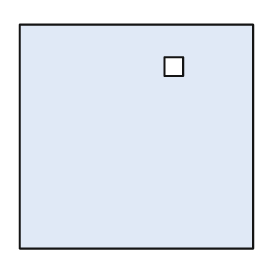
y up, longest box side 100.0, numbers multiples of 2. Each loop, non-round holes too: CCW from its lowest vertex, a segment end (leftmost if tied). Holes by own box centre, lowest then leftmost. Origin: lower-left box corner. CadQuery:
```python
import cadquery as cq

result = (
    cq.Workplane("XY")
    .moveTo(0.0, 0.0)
    .lineTo(100.0, 0.0)
    .lineTo(100.0, 96.0)
    .lineTo(0.0, 96.0)
    .close()
    .moveTo(62.0, 74.0)
    .lineTo(70.0, 74.0)
    .lineTo(70.0, 82.0)
    .lineTo(62.0, 82.0)
    .close()
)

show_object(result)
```